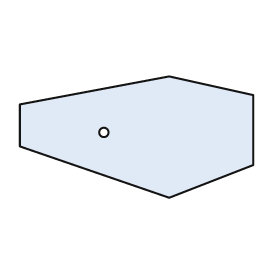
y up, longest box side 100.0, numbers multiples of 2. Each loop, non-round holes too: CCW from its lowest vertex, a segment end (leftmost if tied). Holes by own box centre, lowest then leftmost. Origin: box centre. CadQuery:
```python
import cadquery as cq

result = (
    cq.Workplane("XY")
    .moveTo(14.0, -26.0)
    .lineTo(50.0, -12.0)
    .lineTo(50.0, 18.0)
    .lineTo(14.0, 26.0)
    .lineTo(-50.0, 14.0)
    .lineTo(-50.0, -4.0)
    .close()
    .moveTo(-14.0, 2.0)
    .circle(2.0)
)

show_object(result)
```